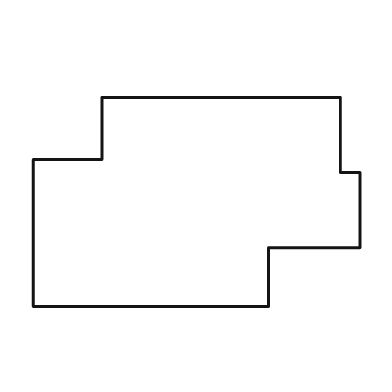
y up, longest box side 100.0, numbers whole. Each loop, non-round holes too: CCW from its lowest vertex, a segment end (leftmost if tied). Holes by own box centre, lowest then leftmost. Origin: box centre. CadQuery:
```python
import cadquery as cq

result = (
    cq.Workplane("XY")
    .moveTo(-50.0, -32.0)
    .lineTo(22.0, -32.0)
    .lineTo(22.0, -14.0)
    .lineTo(50.0, -14.0)
    .lineTo(50.0, 9.0)
    .lineTo(44.0, 9.0)
    .lineTo(44.0, 32.0)
    .lineTo(-29.0, 32.0)
    .lineTo(-29.0, 13.0)
    .lineTo(-50.0, 13.0)
    .close()
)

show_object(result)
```